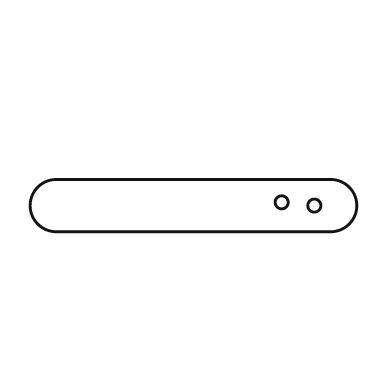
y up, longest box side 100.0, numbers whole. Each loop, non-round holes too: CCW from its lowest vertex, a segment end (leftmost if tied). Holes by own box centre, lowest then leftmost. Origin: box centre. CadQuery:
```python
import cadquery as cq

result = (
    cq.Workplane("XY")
    .moveTo(-42.0, -8.0)
    .lineTo(42.0, -8.0)
    .threePointArc((50.0, 0.0), (42.0, 8.0))
    .lineTo(-42.0, 8.0)
    .threePointArc((-50.0, 0.0), (-42.0, -8.0))
    .close()
    .moveTo(37.0, 0.0)
    .circle(2.0)
    .moveTo(27.0, 1.0)
    .circle(2.0)
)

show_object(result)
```